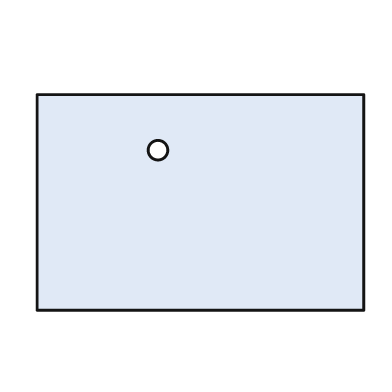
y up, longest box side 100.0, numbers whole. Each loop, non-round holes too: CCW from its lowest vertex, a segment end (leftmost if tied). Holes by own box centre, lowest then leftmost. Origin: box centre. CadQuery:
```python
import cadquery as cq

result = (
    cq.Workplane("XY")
    .moveTo(-50.0, -33.0)
    .lineTo(50.0, -33.0)
    .lineTo(50.0, 33.0)
    .lineTo(-50.0, 33.0)
    .close()
    .moveTo(-13.0, 16.0)
    .circle(3.0)
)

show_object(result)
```